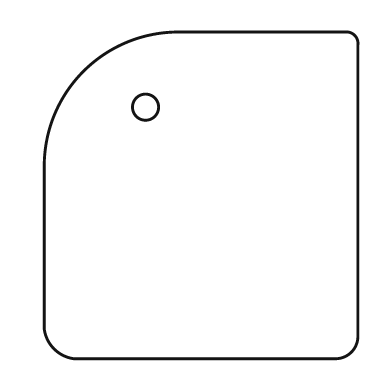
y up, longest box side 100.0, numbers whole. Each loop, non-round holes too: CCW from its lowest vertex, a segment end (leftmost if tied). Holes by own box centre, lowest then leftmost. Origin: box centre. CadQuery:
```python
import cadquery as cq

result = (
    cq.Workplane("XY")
    .moveTo(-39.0, -50.0)
    .lineTo(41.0, -50.0)
    .threePointArc((46.0, -48.0), (48.0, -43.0))
    .lineTo(48.0, 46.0)
    .threePointArc((47.0, 49.0), (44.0, 50.0))
    .lineTo(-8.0, 50.0)
    .threePointArc((-36.0, 38.0), (-48.0, 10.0))
    .lineTo(-48.0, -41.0)
    .threePointArc((-45.0, -47.0), (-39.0, -50.0))
    .close()
    .moveTo(-17.0, 27.0)
    .circle(4.0)
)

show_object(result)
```